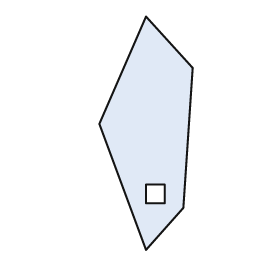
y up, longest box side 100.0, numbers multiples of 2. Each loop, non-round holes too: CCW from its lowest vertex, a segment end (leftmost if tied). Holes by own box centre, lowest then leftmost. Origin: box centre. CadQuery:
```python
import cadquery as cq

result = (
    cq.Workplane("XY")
    .moveTo(0.0, -50.0)
    .lineTo(16.0, -32.0)
    .lineTo(20.0, 28.0)
    .lineTo(0.0, 50.0)
    .lineTo(-20.0, 4.0)
    .close()
    .moveTo(0.0, -30.0)
    .lineTo(8.0, -30.0)
    .lineTo(8.0, -22.0)
    .lineTo(0.0, -22.0)
    .close()
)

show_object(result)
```